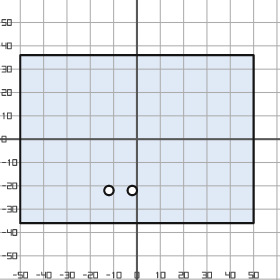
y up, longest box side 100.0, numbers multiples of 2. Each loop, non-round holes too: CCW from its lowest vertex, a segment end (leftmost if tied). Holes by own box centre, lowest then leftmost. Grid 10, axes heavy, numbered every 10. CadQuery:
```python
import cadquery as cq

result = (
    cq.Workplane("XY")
    .moveTo(-50.0, -36.0)
    .lineTo(50.0, -36.0)
    .lineTo(50.0, 36.0)
    .lineTo(-50.0, 36.0)
    .close()
    .moveTo(-12.0, -22.0)
    .circle(2.0)
    .moveTo(-2.0, -22.0)
    .circle(2.0)
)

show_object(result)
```